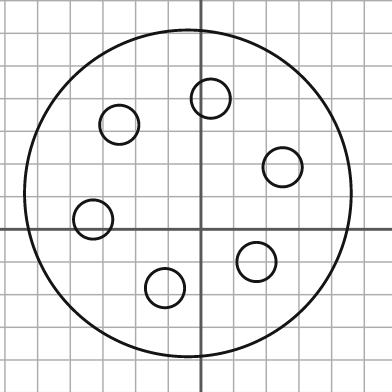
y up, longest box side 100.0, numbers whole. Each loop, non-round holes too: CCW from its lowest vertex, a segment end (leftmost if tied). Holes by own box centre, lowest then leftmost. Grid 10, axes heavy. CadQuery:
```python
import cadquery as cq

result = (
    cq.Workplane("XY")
    .moveTo(-4.0, 11.0)
    .circle(50.0)
    .moveTo(-11.0, -18.0)
    .circle(6.0)
    .moveTo(17.0, -10.0)
    .circle(6.0)
    .moveTo(-33.0, 3.0)
    .circle(6.0)
    .moveTo(25.0, 19.0)
    .circle(6.0)
    .moveTo(-25.0, 32.0)
    .circle(6.0)
    .moveTo(3.0, 40.0)
    .circle(6.0)
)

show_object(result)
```